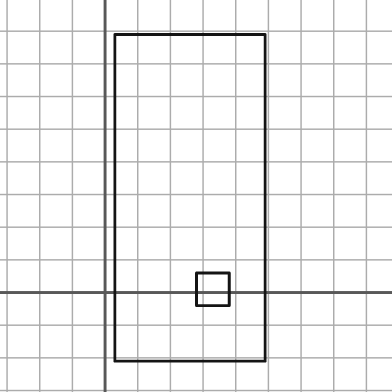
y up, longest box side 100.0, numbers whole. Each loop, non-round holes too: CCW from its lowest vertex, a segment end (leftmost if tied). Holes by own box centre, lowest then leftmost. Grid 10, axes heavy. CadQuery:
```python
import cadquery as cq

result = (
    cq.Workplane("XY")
    .moveTo(3.0, -21.0)
    .lineTo(49.0, -21.0)
    .lineTo(49.0, 79.0)
    .lineTo(3.0, 79.0)
    .close()
    .moveTo(28.0, -4.0)
    .lineTo(38.0, -4.0)
    .lineTo(38.0, 6.0)
    .lineTo(28.0, 6.0)
    .close()
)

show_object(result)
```